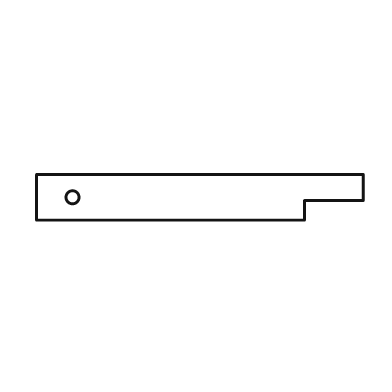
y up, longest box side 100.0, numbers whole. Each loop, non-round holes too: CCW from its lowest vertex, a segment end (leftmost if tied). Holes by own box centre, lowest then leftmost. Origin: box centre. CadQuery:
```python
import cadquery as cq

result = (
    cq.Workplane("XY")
    .moveTo(-50.0, -7.0)
    .lineTo(32.0, -7.0)
    .lineTo(32.0, -1.0)
    .lineTo(50.0, -1.0)
    .lineTo(50.0, 7.0)
    .lineTo(-50.0, 7.0)
    .close()
    .moveTo(-39.0, 0.0)
    .circle(2.0)
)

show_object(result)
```